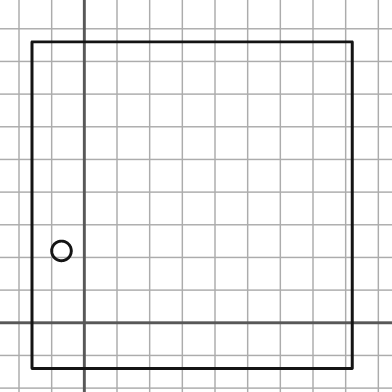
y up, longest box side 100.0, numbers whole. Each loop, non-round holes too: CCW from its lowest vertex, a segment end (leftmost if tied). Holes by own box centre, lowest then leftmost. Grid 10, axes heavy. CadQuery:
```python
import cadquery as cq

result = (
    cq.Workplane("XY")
    .moveTo(-16.0, -14.0)
    .lineTo(82.0, -14.0)
    .lineTo(82.0, 86.0)
    .lineTo(-16.0, 86.0)
    .close()
    .moveTo(-7.0, 22.0)
    .circle(3.0)
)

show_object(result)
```